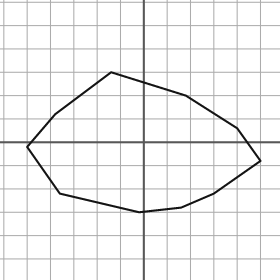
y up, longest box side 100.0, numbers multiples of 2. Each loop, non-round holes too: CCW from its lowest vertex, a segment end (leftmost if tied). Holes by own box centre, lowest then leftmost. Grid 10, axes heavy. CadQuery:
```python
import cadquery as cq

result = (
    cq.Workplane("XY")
    .moveTo(-2.0, -30.0)
    .lineTo(16.0, -28.0)
    .lineTo(30.0, -22.0)
    .lineTo(50.0, -8.0)
    .lineTo(40.0, 6.0)
    .lineTo(18.0, 20.0)
    .lineTo(-14.0, 30.0)
    .lineTo(-38.0, 12.0)
    .lineTo(-50.0, -2.0)
    .lineTo(-36.0, -22.0)
    .close()
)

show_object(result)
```